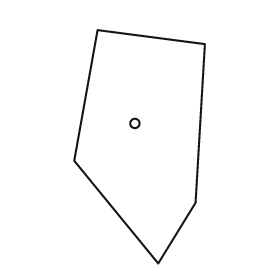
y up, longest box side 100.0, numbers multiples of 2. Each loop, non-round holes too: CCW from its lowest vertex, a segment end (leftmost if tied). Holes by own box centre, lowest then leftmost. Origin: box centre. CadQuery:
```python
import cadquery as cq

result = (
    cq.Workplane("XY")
    .moveTo(8.0, -50.0)
    .lineTo(24.0, -24.0)
    .lineTo(28.0, 44.0)
    .lineTo(-18.0, 50.0)
    .lineTo(-28.0, -6.0)
    .close()
    .moveTo(-2.0, 10.0)
    .circle(2.0)
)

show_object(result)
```